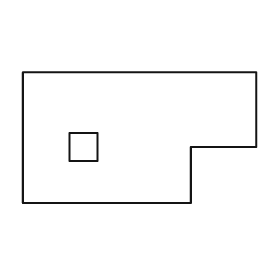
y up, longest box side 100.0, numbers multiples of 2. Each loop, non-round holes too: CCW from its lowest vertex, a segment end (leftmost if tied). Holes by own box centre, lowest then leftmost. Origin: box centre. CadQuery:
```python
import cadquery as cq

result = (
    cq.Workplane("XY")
    .moveTo(-50.0, -28.0)
    .lineTo(22.0, -28.0)
    .lineTo(22.0, -4.0)
    .lineTo(50.0, -4.0)
    .lineTo(50.0, 28.0)
    .lineTo(-50.0, 28.0)
    .close()
    .moveTo(-30.0, -10.0)
    .lineTo(-18.0, -10.0)
    .lineTo(-18.0, 2.0)
    .lineTo(-30.0, 2.0)
    .close()
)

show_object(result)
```